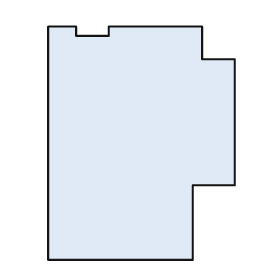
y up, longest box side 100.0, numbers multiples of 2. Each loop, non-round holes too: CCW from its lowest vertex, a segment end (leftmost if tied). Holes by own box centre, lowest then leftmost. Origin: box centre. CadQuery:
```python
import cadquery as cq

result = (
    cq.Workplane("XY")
    .moveTo(-40.0, -50.0)
    .lineTo(22.0, -50.0)
    .lineTo(22.0, -18.0)
    .lineTo(40.0, -18.0)
    .lineTo(40.0, 36.0)
    .lineTo(26.0, 36.0)
    .lineTo(26.0, 50.0)
    .lineTo(-14.0, 50.0)
    .lineTo(-14.0, 46.0)
    .lineTo(-28.0, 46.0)
    .lineTo(-28.0, 50.0)
    .lineTo(-40.0, 50.0)
    .close()
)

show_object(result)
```